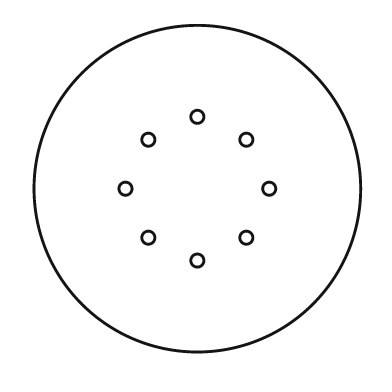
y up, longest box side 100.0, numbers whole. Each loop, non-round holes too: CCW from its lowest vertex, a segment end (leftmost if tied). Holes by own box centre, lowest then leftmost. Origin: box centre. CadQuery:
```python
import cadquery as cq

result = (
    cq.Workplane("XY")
    .moveTo(0.0, 0.0)
    .circle(50.0)
    .moveTo(0.0, -22.0)
    .circle(2.0)
    .moveTo(-15.0, -15.0)
    .circle(2.0)
    .moveTo(15.0, -15.0)
    .circle(2.0)
    .moveTo(-22.0, 0.0)
    .circle(2.0)
    .moveTo(22.0, 0.0)
    .circle(2.0)
    .moveTo(-15.0, 15.0)
    .circle(2.0)
    .moveTo(15.0, 15.0)
    .circle(2.0)
    .moveTo(0.0, 22.0)
    .circle(2.0)
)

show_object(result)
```